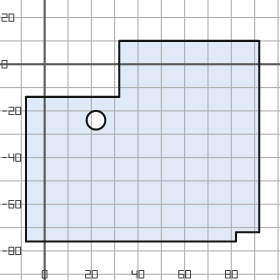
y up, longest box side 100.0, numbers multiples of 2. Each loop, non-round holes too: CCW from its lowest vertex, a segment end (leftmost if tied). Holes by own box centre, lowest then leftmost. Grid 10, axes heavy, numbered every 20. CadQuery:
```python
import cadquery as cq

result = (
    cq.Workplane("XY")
    .moveTo(-8.0, -76.0)
    .lineTo(82.0, -76.0)
    .lineTo(82.0, -72.0)
    .lineTo(92.0, -72.0)
    .lineTo(92.0, 10.0)
    .lineTo(32.0, 10.0)
    .lineTo(32.0, -14.0)
    .lineTo(-8.0, -14.0)
    .close()
    .moveTo(22.0, -24.0)
    .circle(4.0)
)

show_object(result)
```